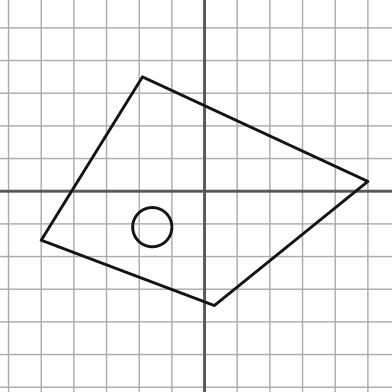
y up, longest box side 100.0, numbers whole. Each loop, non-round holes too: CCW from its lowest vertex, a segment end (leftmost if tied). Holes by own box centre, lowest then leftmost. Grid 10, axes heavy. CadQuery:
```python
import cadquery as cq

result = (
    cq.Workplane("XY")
    .moveTo(3.0, -35.0)
    .lineTo(50.0, 3.0)
    .lineTo(-19.0, 35.0)
    .lineTo(-50.0, -15.0)
    .close()
    .moveTo(-16.0, -11.0)
    .circle(6.0)
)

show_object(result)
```